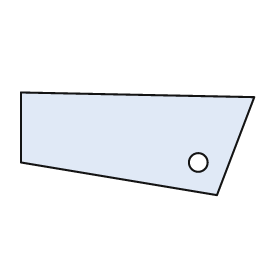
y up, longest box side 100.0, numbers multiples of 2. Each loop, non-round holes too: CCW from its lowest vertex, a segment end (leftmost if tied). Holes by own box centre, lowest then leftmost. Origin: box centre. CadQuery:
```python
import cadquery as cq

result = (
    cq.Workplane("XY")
    .moveTo(34.0, -22.0)
    .lineTo(50.0, 20.0)
    .lineTo(-50.0, 22.0)
    .lineTo(-50.0, -8.0)
    .close()
    .moveTo(26.0, -8.0)
    .circle(4.0)
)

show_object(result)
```